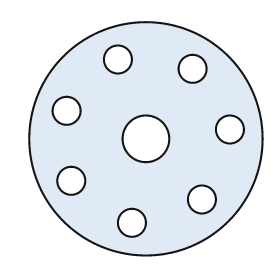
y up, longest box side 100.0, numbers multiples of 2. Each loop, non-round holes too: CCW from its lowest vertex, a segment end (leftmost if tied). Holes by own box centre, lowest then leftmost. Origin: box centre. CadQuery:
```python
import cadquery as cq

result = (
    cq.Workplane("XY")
    .moveTo(0.0, 0.0)
    .circle(50.0)
    .moveTo(-6.0, -36.0)
    .circle(6.0)
    .moveTo(24.0, -26.0)
    .circle(6.0)
    .moveTo(-32.0, -18.0)
    .circle(6.0)
    .moveTo(0.0, 0.0)
    .circle(10.0)
    .moveTo(36.0, 4.0)
    .circle(6.0)
    .moveTo(-34.0, 12.0)
    .circle(6.0)
    .moveTo(20.0, 30.0)
    .circle(6.0)
    .moveTo(-12.0, 34.0)
    .circle(6.0)
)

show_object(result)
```